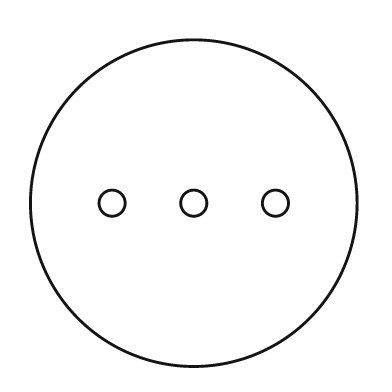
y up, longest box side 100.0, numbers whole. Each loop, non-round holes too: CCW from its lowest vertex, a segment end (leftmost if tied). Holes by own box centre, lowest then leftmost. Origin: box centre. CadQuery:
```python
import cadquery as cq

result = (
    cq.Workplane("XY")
    .moveTo(0.0, 0.0)
    .circle(50.0)
    .moveTo(-25.0, 0.0)
    .circle(4.0)
    .moveTo(0.0, 0.0)
    .circle(4.0)
    .moveTo(25.0, 0.0)
    .circle(4.0)
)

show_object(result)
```